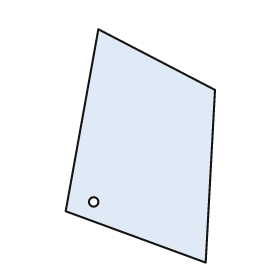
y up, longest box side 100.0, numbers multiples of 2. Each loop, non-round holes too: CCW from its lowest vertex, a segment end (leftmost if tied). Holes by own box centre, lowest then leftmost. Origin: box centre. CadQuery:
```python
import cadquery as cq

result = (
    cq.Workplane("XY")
    .moveTo(28.0, -50.0)
    .lineTo(32.0, 24.0)
    .lineTo(-18.0, 50.0)
    .lineTo(-32.0, -28.0)
    .close()
    .moveTo(-20.0, -24.0)
    .circle(2.0)
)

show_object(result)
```